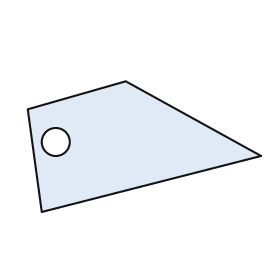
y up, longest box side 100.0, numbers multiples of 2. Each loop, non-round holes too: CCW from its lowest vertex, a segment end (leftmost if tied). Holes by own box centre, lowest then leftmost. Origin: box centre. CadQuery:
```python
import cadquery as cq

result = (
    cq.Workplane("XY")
    .moveTo(-44.0, -28.0)
    .lineTo(50.0, -4.0)
    .lineTo(-8.0, 28.0)
    .lineTo(-50.0, 16.0)
    .close()
    .moveTo(-38.0, 2.0)
    .circle(6.0)
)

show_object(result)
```